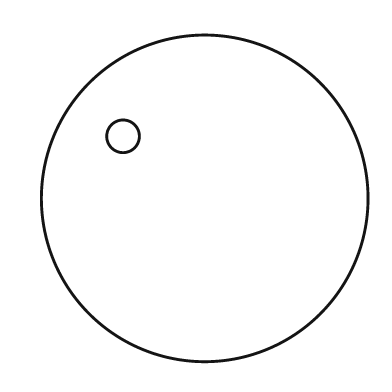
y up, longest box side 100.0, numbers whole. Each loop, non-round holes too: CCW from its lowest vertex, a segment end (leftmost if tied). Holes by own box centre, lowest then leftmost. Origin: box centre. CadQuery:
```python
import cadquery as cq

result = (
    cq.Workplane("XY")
    .moveTo(0.0, 0.0)
    .circle(50.0)
    .moveTo(-25.0, 19.0)
    .circle(5.0)
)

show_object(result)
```